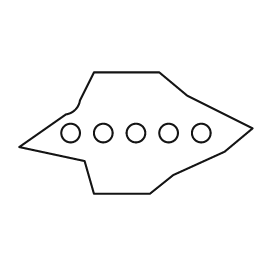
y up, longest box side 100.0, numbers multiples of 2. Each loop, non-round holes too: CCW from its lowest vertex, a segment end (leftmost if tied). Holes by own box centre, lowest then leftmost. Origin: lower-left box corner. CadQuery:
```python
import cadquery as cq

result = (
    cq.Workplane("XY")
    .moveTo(32.0, 0.0)
    .lineTo(56.0, 0.0)
    .lineTo(66.0, 8.0)
    .lineTo(88.0, 18.0)
    .lineTo(100.0, 28.0)
    .lineTo(72.0, 42.0)
    .lineTo(60.0, 52.0)
    .lineTo(32.0, 52.0)
    .lineTo(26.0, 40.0)
    .threePointArc((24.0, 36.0), (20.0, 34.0))
    .lineTo(0.0, 20.0)
    .lineTo(28.0, 14.0)
    .close()
    .moveTo(22.0, 26.0)
    .circle(4.0)
    .moveTo(36.0, 26.0)
    .circle(4.0)
    .moveTo(50.0, 26.0)
    .circle(4.0)
    .moveTo(64.0, 26.0)
    .circle(4.0)
    .moveTo(78.0, 26.0)
    .circle(4.0)
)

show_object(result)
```